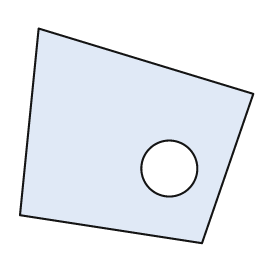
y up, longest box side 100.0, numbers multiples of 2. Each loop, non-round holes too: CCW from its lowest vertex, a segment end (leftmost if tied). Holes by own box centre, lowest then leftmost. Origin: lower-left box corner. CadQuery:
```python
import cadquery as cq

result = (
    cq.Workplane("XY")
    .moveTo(78.0, 0.0)
    .lineTo(100.0, 64.0)
    .lineTo(8.0, 92.0)
    .lineTo(0.0, 12.0)
    .close()
    .moveTo(64.0, 32.0)
    .circle(12.0)
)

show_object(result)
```